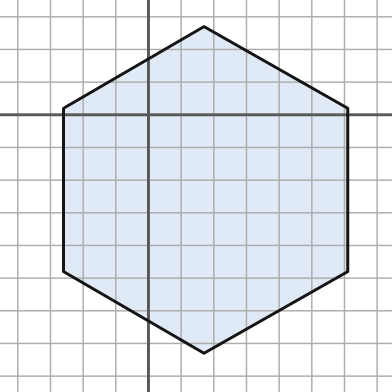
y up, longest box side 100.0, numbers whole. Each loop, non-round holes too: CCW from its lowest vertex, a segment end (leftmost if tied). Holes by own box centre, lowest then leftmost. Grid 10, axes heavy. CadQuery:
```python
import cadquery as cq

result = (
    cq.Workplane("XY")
    .moveTo(17.0, -73.0)
    .lineTo(61.0, -48.0)
    .lineTo(61.0, 2.0)
    .lineTo(17.0, 27.0)
    .lineTo(-26.0, 2.0)
    .lineTo(-26.0, -48.0)
    .close()
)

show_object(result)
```